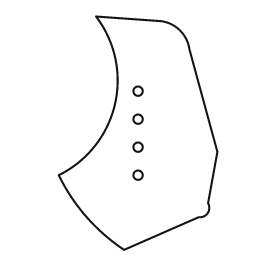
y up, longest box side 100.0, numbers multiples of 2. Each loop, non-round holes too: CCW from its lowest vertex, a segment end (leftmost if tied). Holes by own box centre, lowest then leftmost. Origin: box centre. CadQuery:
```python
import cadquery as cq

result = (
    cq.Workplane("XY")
    .moveTo(-6.0, -50.0)
    .lineTo(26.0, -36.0)
    .threePointArc((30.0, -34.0), (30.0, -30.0))
    .lineTo(34.0, -8.0)
    .lineTo(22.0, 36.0)
    .threePointArc((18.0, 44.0), (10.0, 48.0))
    .lineTo(-18.0, 50.0)
    .threePointArc((-10.0, 12.0), (-34.0, -18.0))
    .threePointArc((-22.0, -36.0), (-6.0, -50.0))
    .close()
    .moveTo(0.0, -18.0)
    .circle(2.0)
    .moveTo(0.0, -6.0)
    .circle(2.0)
    .moveTo(0.0, 6.0)
    .circle(2.0)
    .moveTo(0.0, 18.0)
    .circle(2.0)
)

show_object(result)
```